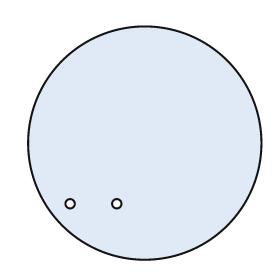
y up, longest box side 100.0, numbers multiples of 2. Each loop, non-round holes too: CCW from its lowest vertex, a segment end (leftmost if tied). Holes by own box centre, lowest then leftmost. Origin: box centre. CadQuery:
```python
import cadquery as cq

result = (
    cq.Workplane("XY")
    .moveTo(0.0, 0.0)
    .circle(50.0)
    .moveTo(-32.0, -26.0)
    .circle(2.0)
    .moveTo(-12.0, -26.0)
    .circle(2.0)
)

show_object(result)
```